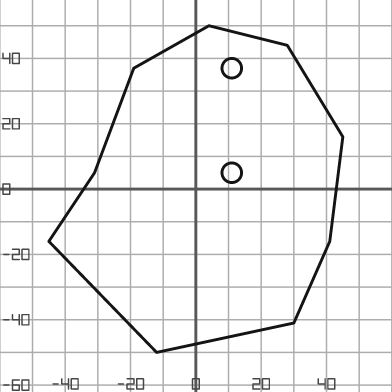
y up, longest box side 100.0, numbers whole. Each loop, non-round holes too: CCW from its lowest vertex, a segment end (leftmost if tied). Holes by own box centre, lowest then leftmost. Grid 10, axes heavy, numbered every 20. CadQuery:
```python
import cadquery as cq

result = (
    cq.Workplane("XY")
    .moveTo(-12.0, -50.0)
    .lineTo(30.0, -41.0)
    .lineTo(41.0, -16.0)
    .lineTo(45.0, 16.0)
    .lineTo(28.0, 44.0)
    .lineTo(4.0, 50.0)
    .lineTo(-19.0, 37.0)
    .lineTo(-31.0, 5.0)
    .lineTo(-45.0, -16.0)
    .close()
    .moveTo(11.0, 5.0)
    .circle(3.0)
    .moveTo(11.0, 37.0)
    .circle(3.0)
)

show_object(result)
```